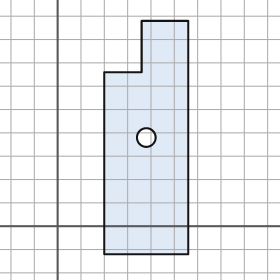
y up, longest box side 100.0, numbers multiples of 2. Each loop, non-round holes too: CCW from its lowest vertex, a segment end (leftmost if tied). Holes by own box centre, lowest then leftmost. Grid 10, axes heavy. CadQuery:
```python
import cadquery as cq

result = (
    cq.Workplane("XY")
    .moveTo(20.0, -12.0)
    .lineTo(56.0, -12.0)
    .lineTo(56.0, 88.0)
    .lineTo(36.0, 88.0)
    .lineTo(36.0, 66.0)
    .lineTo(20.0, 66.0)
    .close()
    .moveTo(38.0, 38.0)
    .circle(4.0)
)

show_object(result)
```